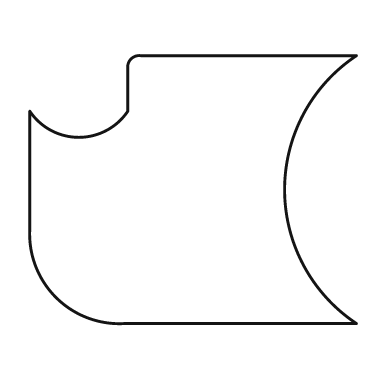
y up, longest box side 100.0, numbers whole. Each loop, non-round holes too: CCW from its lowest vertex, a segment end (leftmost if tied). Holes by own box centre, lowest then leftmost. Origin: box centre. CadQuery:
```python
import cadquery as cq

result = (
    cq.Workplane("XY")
    .moveTo(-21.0, -41.0)
    .lineTo(50.0, -41.0)
    .threePointArc((28.0, 0.0), (50.0, 41.0))
    .lineTo(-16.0, 41.0)
    .threePointArc((-19.0, 40.0), (-20.0, 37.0))
    .lineTo(-20.0, 24.0)
    .threePointArc((-35.0, 16.0), (-50.0, 24.0))
    .lineTo(-50.0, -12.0)
    .threePointArc((-42.0, -33.0), (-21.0, -41.0))
    .close()
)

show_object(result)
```